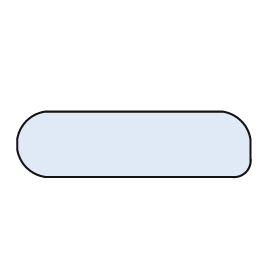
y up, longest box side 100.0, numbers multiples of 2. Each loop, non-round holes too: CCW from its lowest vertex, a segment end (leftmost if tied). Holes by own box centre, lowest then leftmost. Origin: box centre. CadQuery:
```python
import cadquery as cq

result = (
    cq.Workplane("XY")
    .moveTo(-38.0, -14.0)
    .lineTo(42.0, -14.0)
    .threePointArc((48.0, -12.0), (50.0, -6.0))
    .lineTo(50.0, 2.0)
    .threePointArc((46.0, 10.0), (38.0, 14.0))
    .lineTo(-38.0, 14.0)
    .threePointArc((-46.0, 10.0), (-50.0, 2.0))
    .lineTo(-50.0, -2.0)
    .threePointArc((-46.0, -10.0), (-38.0, -14.0))
    .close()
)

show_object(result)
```